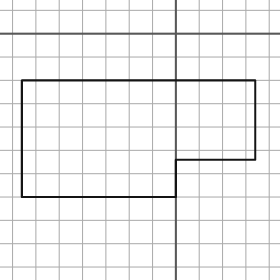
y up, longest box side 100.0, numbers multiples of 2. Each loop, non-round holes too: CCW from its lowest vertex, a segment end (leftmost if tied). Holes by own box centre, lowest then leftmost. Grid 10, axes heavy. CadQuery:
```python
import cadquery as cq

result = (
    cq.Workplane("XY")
    .moveTo(-66.0, -70.0)
    .lineTo(0.0, -70.0)
    .lineTo(0.0, -54.0)
    .lineTo(34.0, -54.0)
    .lineTo(34.0, -20.0)
    .lineTo(-66.0, -20.0)
    .close()
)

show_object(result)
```